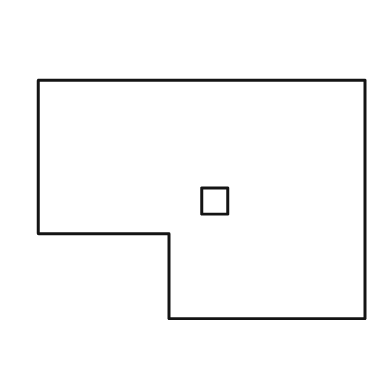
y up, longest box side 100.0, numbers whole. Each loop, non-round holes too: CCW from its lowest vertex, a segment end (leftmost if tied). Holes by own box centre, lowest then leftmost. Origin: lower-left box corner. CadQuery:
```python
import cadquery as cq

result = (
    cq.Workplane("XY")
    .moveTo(40.0, 0.0)
    .lineTo(100.0, 0.0)
    .lineTo(100.0, 73.0)
    .lineTo(0.0, 73.0)
    .lineTo(0.0, 26.0)
    .lineTo(40.0, 26.0)
    .close()
    .moveTo(50.0, 32.0)
    .lineTo(58.0, 32.0)
    .lineTo(58.0, 40.0)
    .lineTo(50.0, 40.0)
    .close()
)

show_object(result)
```